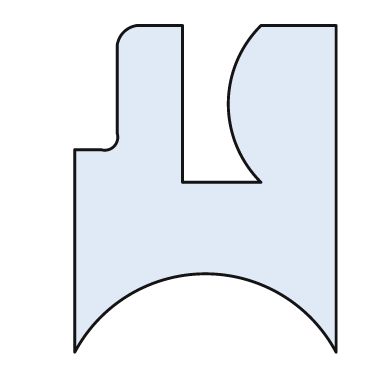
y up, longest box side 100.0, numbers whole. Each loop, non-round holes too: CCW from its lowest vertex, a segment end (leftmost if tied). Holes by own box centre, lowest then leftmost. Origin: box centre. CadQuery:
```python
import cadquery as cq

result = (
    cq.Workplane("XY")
    .moveTo(-40.0, -50.0)
    .threePointArc((0.0, -26.0), (40.0, -50.0))
    .lineTo(40.0, 50.0)
    .lineTo(17.0, 50.0)
    .threePointArc((7.0, 26.0), (17.0, 2.0))
    .lineTo(-7.0, 2.0)
    .lineTo(-7.0, 50.0)
    .lineTo(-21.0, 50.0)
    .threePointArc((-25.0, 48.0), (-27.0, 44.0))
    .lineTo(-27.0, 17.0)
    .threePointArc((-28.0, 13.0), (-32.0, 12.0))
    .lineTo(-40.0, 12.0)
    .close()
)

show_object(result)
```